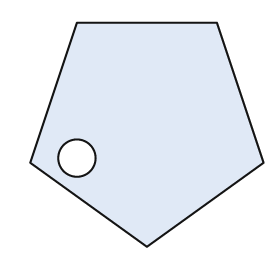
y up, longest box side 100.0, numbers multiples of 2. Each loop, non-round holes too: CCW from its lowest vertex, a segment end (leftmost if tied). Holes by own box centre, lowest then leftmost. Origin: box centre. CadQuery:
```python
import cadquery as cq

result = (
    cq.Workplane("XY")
    .moveTo(0.0, -48.0)
    .lineTo(50.0, -12.0)
    .lineTo(30.0, 48.0)
    .lineTo(-30.0, 48.0)
    .lineTo(-50.0, -12.0)
    .close()
    .moveTo(-30.0, -10.0)
    .circle(8.0)
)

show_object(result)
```